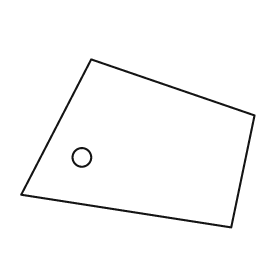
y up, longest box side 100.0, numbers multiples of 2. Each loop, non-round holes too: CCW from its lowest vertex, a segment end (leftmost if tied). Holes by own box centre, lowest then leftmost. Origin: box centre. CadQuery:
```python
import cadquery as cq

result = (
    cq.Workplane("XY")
    .moveTo(40.0, -36.0)
    .lineTo(50.0, 12.0)
    .lineTo(-20.0, 36.0)
    .lineTo(-50.0, -22.0)
    .close()
    .moveTo(-24.0, -6.0)
    .circle(4.0)
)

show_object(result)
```